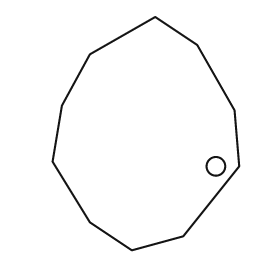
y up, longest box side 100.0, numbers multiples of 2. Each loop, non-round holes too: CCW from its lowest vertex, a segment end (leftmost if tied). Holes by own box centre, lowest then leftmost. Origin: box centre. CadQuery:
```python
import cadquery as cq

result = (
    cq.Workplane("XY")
    .moveTo(-6.0, -50.0)
    .lineTo(16.0, -44.0)
    .lineTo(40.0, -14.0)
    .lineTo(38.0, 10.0)
    .lineTo(22.0, 38.0)
    .lineTo(4.0, 50.0)
    .lineTo(-24.0, 34.0)
    .lineTo(-36.0, 12.0)
    .lineTo(-40.0, -12.0)
    .lineTo(-24.0, -38.0)
    .close()
    .moveTo(30.0, -14.0)
    .circle(4.0)
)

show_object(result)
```